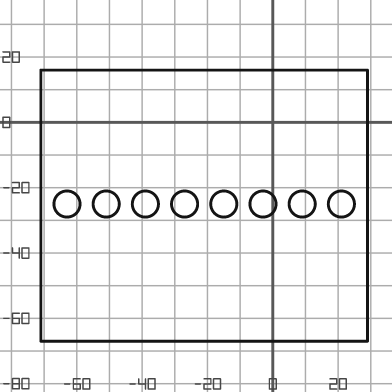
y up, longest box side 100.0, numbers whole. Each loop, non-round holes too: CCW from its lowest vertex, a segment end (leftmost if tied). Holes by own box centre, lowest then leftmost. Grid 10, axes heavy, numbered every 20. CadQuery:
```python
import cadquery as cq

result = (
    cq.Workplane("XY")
    .moveTo(-71.0, -67.0)
    .lineTo(29.0, -67.0)
    .lineTo(29.0, 16.0)
    .lineTo(-71.0, 16.0)
    .close()
    .moveTo(-63.0, -25.0)
    .circle(4.0)
    .moveTo(-51.0, -25.0)
    .circle(4.0)
    .moveTo(-39.0, -25.0)
    .circle(4.0)
    .moveTo(-27.0, -25.0)
    .circle(4.0)
    .moveTo(-15.0, -25.0)
    .circle(4.0)
    .moveTo(-3.0, -25.0)
    .circle(4.0)
    .moveTo(9.0, -25.0)
    .circle(4.0)
    .moveTo(21.0, -25.0)
    .circle(4.0)
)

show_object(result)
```